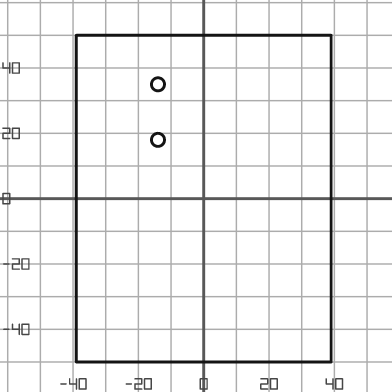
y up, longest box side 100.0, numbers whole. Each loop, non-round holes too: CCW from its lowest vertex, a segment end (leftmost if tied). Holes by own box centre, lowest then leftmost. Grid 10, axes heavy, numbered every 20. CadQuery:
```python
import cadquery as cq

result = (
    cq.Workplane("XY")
    .moveTo(-39.0, -50.0)
    .lineTo(39.0, -50.0)
    .lineTo(39.0, 50.0)
    .lineTo(-39.0, 50.0)
    .close()
    .moveTo(-14.0, 18.0)
    .circle(2.0)
    .moveTo(-14.0, 35.0)
    .circle(2.0)
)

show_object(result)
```